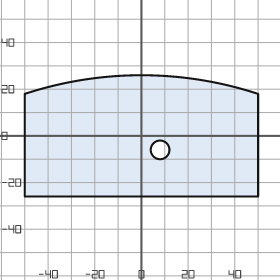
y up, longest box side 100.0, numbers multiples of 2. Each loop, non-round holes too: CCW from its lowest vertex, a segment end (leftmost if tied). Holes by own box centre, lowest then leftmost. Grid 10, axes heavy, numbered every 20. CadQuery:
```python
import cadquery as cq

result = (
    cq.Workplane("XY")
    .moveTo(-50.0, -26.0)
    .lineTo(50.0, -26.0)
    .lineTo(50.0, 18.0)
    .threePointArc((0.0, 26.0), (-50.0, 18.0))
    .close()
    .moveTo(8.0, -6.0)
    .circle(4.0)
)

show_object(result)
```